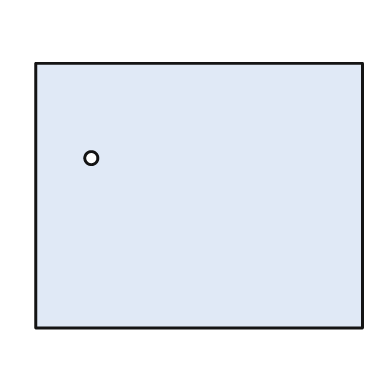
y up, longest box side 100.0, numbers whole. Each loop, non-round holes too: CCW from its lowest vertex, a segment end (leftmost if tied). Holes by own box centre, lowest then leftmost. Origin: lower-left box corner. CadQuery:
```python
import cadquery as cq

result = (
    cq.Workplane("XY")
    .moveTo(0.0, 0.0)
    .lineTo(100.0, 0.0)
    .lineTo(100.0, 81.0)
    .lineTo(0.0, 81.0)
    .close()
    .moveTo(17.0, 52.0)
    .circle(2.0)
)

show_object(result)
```